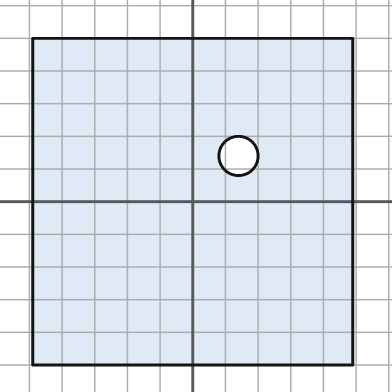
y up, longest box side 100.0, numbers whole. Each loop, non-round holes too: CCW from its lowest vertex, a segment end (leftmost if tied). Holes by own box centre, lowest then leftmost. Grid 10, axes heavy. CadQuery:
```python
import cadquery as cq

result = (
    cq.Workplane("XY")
    .moveTo(-49.0, -50.0)
    .lineTo(49.0, -50.0)
    .lineTo(49.0, 50.0)
    .lineTo(-49.0, 50.0)
    .close()
    .moveTo(14.0, 14.0)
    .circle(6.0)
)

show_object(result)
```